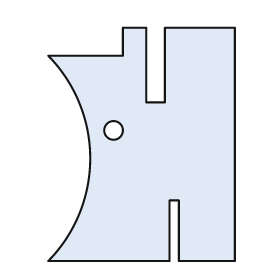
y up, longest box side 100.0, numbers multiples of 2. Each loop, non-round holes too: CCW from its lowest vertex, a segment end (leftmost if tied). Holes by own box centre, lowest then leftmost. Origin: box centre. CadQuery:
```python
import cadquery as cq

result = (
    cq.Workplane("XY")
    .moveTo(-40.0, -50.0)
    .lineTo(12.0, -50.0)
    .lineTo(12.0, -24.0)
    .lineTo(16.0, -24.0)
    .lineTo(16.0, -50.0)
    .lineTo(40.0, -50.0)
    .lineTo(40.0, 50.0)
    .lineTo(10.0, 50.0)
    .lineTo(10.0, 18.0)
    .lineTo(2.0, 18.0)
    .lineTo(2.0, 50.0)
    .lineTo(-8.0, 50.0)
    .lineTo(-8.0, 38.0)
    .lineTo(-40.0, 38.0)
    .threePointArc((-22.0, -6.0), (-40.0, -50.0))
    .close()
    .moveTo(-12.0, 6.0)
    .circle(4.0)
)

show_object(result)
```